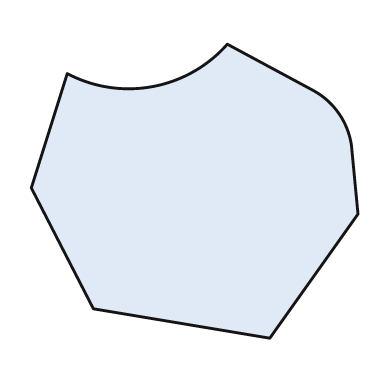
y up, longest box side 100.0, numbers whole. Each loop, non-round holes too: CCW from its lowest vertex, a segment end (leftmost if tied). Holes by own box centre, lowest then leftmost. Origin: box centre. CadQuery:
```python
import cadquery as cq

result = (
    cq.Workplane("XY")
    .moveTo(23.0, -45.0)
    .lineTo(50.0, -7.0)
    .lineTo(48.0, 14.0)
    .threePointArc((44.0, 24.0), (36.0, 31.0))
    .lineTo(10.0, 45.0)
    .threePointArc((-13.0, 32.0), (-39.0, 36.0))
    .lineTo(-50.0, 1.0)
    .lineTo(-31.0, -36.0)
    .close()
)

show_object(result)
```